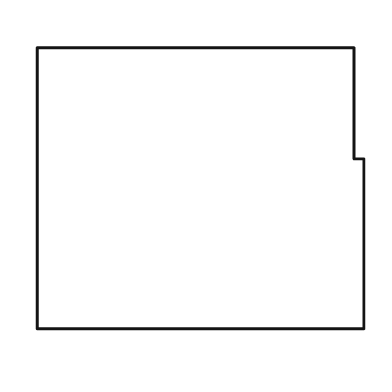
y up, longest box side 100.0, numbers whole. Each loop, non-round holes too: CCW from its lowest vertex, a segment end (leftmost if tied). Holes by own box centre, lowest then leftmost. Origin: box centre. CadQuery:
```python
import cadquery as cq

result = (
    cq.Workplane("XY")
    .moveTo(-50.0, -43.0)
    .lineTo(50.0, -43.0)
    .lineTo(50.0, 9.0)
    .lineTo(47.0, 9.0)
    .lineTo(47.0, 43.0)
    .lineTo(-50.0, 43.0)
    .close()
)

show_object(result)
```